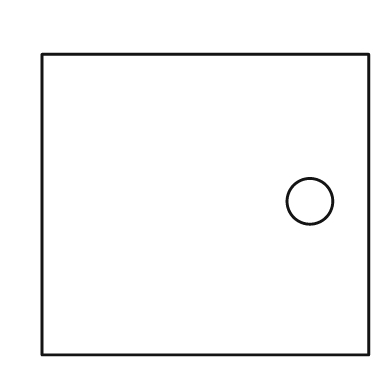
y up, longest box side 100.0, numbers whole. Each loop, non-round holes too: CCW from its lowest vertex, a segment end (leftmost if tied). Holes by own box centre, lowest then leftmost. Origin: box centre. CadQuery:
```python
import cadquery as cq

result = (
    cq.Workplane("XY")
    .moveTo(-50.0, -46.0)
    .lineTo(50.0, -46.0)
    .lineTo(50.0, 46.0)
    .lineTo(-50.0, 46.0)
    .close()
    .moveTo(32.0, 1.0)
    .circle(7.0)
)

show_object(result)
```